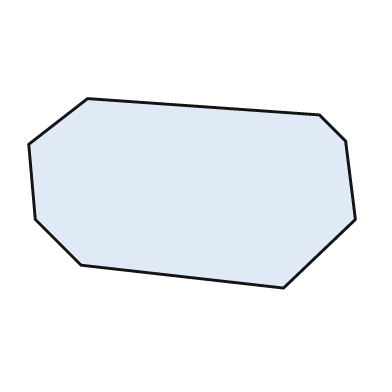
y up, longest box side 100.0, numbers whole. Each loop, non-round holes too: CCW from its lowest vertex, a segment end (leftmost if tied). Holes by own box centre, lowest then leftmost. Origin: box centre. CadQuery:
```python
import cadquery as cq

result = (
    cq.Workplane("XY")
    .moveTo(28.0, -29.0)
    .lineTo(50.0, -8.0)
    .lineTo(47.0, 16.0)
    .lineTo(39.0, 24.0)
    .lineTo(-32.0, 29.0)
    .lineTo(-50.0, 15.0)
    .lineTo(-48.0, -8.0)
    .lineTo(-34.0, -22.0)
    .close()
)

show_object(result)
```